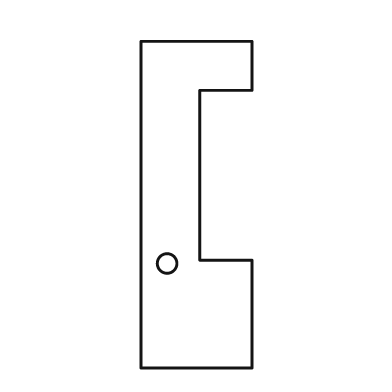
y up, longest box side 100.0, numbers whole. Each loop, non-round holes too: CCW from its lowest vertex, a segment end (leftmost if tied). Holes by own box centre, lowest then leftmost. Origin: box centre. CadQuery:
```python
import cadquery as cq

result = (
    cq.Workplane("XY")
    .moveTo(-17.0, -50.0)
    .lineTo(17.0, -50.0)
    .lineTo(17.0, -17.0)
    .lineTo(1.0, -17.0)
    .lineTo(1.0, 35.0)
    .lineTo(17.0, 35.0)
    .lineTo(17.0, 50.0)
    .lineTo(-17.0, 50.0)
    .close()
    .moveTo(-9.0, -18.0)
    .circle(3.0)
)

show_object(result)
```